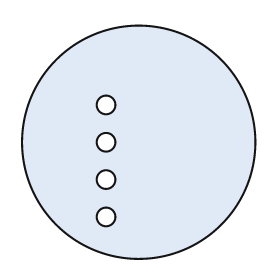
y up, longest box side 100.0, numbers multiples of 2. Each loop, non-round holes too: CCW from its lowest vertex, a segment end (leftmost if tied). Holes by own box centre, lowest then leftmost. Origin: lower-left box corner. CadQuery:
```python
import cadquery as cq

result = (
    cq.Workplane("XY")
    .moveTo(50.0, 50.0)
    .circle(50.0)
    .moveTo(36.0, 18.0)
    .circle(4.0)
    .moveTo(36.0, 34.0)
    .circle(4.0)
    .moveTo(36.0, 50.0)
    .circle(4.0)
    .moveTo(36.0, 66.0)
    .circle(4.0)
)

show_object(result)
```